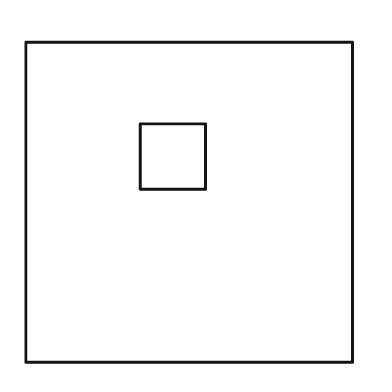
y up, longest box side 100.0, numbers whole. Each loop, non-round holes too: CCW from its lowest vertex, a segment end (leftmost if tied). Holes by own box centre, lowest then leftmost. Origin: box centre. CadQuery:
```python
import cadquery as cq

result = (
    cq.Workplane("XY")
    .moveTo(-50.0, -49.0)
    .lineTo(50.0, -49.0)
    .lineTo(50.0, 49.0)
    .lineTo(-50.0, 49.0)
    .close()
    .moveTo(-15.0, 4.0)
    .lineTo(5.0, 4.0)
    .lineTo(5.0, 24.0)
    .lineTo(-15.0, 24.0)
    .close()
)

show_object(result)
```